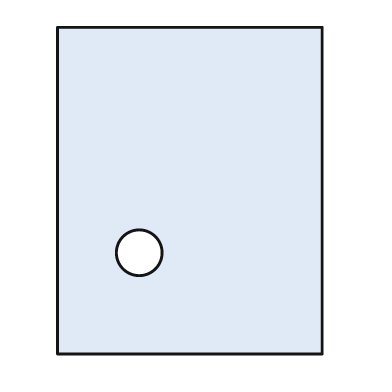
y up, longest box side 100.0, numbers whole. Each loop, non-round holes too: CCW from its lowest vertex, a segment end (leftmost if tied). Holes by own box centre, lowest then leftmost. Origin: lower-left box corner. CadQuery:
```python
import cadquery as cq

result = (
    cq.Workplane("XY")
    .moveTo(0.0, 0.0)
    .lineTo(81.0, 0.0)
    .lineTo(81.0, 100.0)
    .lineTo(0.0, 100.0)
    .close()
    .moveTo(25.0, 31.0)
    .circle(7.0)
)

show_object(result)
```